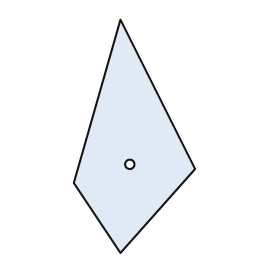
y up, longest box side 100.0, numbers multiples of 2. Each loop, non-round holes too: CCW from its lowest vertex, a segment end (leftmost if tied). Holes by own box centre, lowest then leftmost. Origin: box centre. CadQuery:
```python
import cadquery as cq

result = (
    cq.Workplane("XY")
    .moveTo(-6.0, -50.0)
    .lineTo(26.0, -14.0)
    .lineTo(-6.0, 50.0)
    .lineTo(-26.0, -20.0)
    .close()
    .moveTo(-2.0, -12.0)
    .circle(2.0)
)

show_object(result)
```